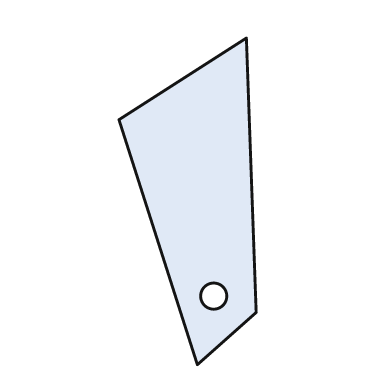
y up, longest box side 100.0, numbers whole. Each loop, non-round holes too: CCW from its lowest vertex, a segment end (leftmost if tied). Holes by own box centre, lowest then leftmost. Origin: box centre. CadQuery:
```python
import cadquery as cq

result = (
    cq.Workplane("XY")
    .moveTo(3.0, -50.0)
    .lineTo(21.0, -34.0)
    .lineTo(18.0, 50.0)
    .lineTo(-21.0, 25.0)
    .close()
    .moveTo(8.0, -29.0)
    .circle(4.0)
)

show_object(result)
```